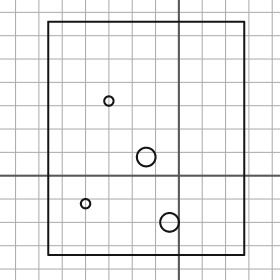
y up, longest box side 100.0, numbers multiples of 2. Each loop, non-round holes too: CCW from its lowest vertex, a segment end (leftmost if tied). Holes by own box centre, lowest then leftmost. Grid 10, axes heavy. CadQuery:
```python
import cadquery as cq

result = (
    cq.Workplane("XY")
    .moveTo(-56.0, -34.0)
    .lineTo(28.0, -34.0)
    .lineTo(28.0, 66.0)
    .lineTo(-56.0, 66.0)
    .close()
    .moveTo(-4.0, -20.0)
    .circle(4.0)
    .moveTo(-40.0, -12.0)
    .circle(2.0)
    .moveTo(-14.0, 8.0)
    .circle(4.0)
    .moveTo(-30.0, 32.0)
    .circle(2.0)
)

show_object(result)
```